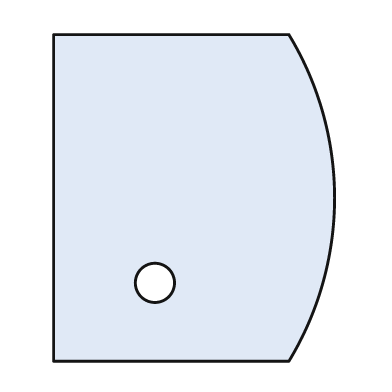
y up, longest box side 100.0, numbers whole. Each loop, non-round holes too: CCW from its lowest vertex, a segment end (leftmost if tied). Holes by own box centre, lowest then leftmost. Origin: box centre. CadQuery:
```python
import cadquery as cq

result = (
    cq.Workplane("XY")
    .moveTo(-43.0, -50.0)
    .lineTo(29.0, -50.0)
    .threePointArc((43.0, 0.0), (29.0, 50.0))
    .lineTo(-43.0, 50.0)
    .close()
    .moveTo(-12.0, -26.0)
    .circle(6.0)
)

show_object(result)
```